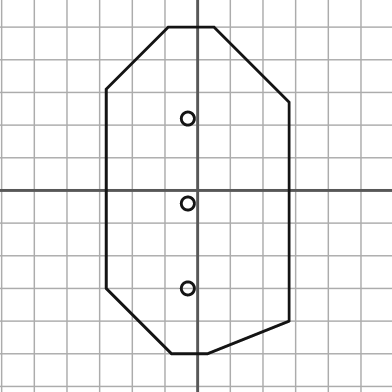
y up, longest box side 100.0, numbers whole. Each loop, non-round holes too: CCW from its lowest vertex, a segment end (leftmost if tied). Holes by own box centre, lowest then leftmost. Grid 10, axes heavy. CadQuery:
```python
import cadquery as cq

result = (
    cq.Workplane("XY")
    .moveTo(-8.0, -50.0)
    .lineTo(3.0, -50.0)
    .lineTo(28.0, -40.0)
    .lineTo(28.0, 27.0)
    .lineTo(5.0, 50.0)
    .lineTo(-9.0, 50.0)
    .lineTo(-28.0, 31.0)
    .lineTo(-28.0, -30.0)
    .close()
    .moveTo(-3.0, -30.0)
    .circle(2.0)
    .moveTo(-3.0, -4.0)
    .circle(2.0)
    .moveTo(-3.0, 22.0)
    .circle(2.0)
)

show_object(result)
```